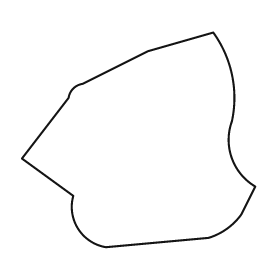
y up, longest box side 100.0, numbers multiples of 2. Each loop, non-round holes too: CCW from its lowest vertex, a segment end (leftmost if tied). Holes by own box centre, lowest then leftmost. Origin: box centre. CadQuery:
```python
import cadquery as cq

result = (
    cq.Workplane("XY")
    .moveTo(-14.0, -46.0)
    .lineTo(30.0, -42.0)
    .threePointArc((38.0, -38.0), (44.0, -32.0))
    .lineTo(50.0, -20.0)
    .threePointArc((40.0, -8.0), (40.0, 8.0))
    .threePointArc((40.0, 28.0), (32.0, 46.0))
    .lineTo(4.0, 38.0)
    .lineTo(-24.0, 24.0)
    .threePointArc((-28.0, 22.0), (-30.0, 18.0))
    .lineTo(-50.0, -8.0)
    .lineTo(-28.0, -24.0)
    .threePointArc((-26.0, -38.0), (-14.0, -46.0))
    .close()
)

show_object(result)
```